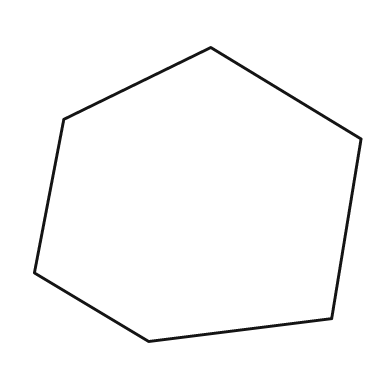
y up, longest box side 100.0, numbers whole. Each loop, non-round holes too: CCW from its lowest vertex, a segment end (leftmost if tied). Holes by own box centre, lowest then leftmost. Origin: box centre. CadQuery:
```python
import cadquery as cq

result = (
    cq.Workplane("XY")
    .moveTo(-15.0, -45.0)
    .lineTo(41.0, -38.0)
    .lineTo(50.0, 17.0)
    .lineTo(4.0, 45.0)
    .lineTo(-41.0, 23.0)
    .lineTo(-50.0, -24.0)
    .close()
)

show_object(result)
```